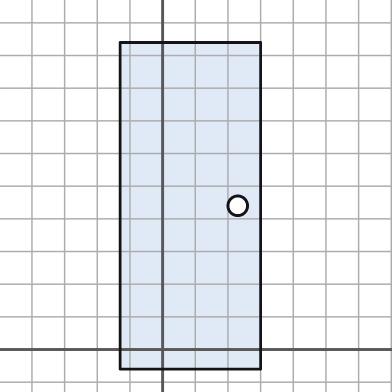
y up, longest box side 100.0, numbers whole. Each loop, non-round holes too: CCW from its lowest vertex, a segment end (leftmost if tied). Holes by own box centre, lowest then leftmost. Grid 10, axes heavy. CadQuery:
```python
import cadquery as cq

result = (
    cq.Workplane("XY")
    .moveTo(-13.0, -6.0)
    .lineTo(30.0, -6.0)
    .lineTo(30.0, 94.0)
    .lineTo(-13.0, 94.0)
    .close()
    .moveTo(23.0, 44.0)
    .circle(3.0)
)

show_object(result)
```